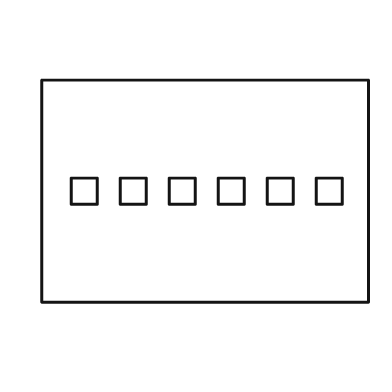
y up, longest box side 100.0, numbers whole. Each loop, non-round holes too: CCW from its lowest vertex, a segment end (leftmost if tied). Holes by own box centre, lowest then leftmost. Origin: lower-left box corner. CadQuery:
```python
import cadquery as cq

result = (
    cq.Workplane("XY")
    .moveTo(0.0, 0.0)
    .lineTo(100.0, 0.0)
    .lineTo(100.0, 68.0)
    .lineTo(0.0, 68.0)
    .close()
    .moveTo(9.0, 30.0)
    .lineTo(17.0, 30.0)
    .lineTo(17.0, 38.0)
    .lineTo(9.0, 38.0)
    .close()
    .moveTo(24.0, 30.0)
    .lineTo(32.0, 30.0)
    .lineTo(32.0, 38.0)
    .lineTo(24.0, 38.0)
    .close()
    .moveTo(39.0, 30.0)
    .lineTo(47.0, 30.0)
    .lineTo(47.0, 38.0)
    .lineTo(39.0, 38.0)
    .close()
    .moveTo(54.0, 30.0)
    .lineTo(62.0, 30.0)
    .lineTo(62.0, 38.0)
    .lineTo(54.0, 38.0)
    .close()
    .moveTo(69.0, 30.0)
    .lineTo(77.0, 30.0)
    .lineTo(77.0, 38.0)
    .lineTo(69.0, 38.0)
    .close()
    .moveTo(84.0, 30.0)
    .lineTo(92.0, 30.0)
    .lineTo(92.0, 38.0)
    .lineTo(84.0, 38.0)
    .close()
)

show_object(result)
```